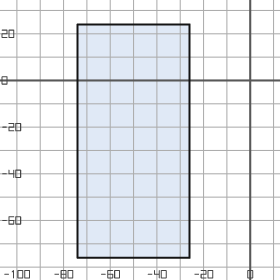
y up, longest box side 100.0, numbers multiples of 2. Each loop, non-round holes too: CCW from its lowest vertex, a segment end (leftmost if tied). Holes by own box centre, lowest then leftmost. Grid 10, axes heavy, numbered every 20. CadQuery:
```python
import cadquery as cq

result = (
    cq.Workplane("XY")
    .moveTo(-74.0, -76.0)
    .lineTo(-26.0, -76.0)
    .lineTo(-26.0, 24.0)
    .lineTo(-74.0, 24.0)
    .close()
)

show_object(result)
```